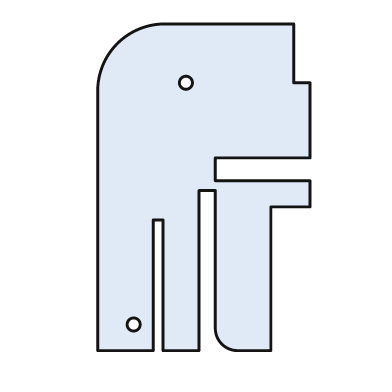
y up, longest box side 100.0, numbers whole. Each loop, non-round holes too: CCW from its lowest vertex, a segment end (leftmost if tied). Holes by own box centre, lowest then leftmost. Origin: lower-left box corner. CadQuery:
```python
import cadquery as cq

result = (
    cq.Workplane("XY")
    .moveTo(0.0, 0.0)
    .lineTo(17.0, 0.0)
    .lineTo(17.0, 40.0)
    .lineTo(20.0, 40.0)
    .lineTo(20.0, 0.0)
    .lineTo(31.0, 0.0)
    .lineTo(31.0, 49.0)
    .lineTo(36.0, 49.0)
    .lineTo(36.0, 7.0)
    .threePointArc((38.0, 2.0), (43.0, 0.0))
    .lineTo(53.0, 0.0)
    .lineTo(53.0, 44.0)
    .lineTo(65.0, 44.0)
    .lineTo(65.0, 52.0)
    .lineTo(36.0, 52.0)
    .lineTo(36.0, 59.0)
    .lineTo(65.0, 59.0)
    .lineTo(65.0, 82.0)
    .lineTo(60.0, 82.0)
    .lineTo(60.0, 100.0)
    .lineTo(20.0, 100.0)
    .threePointArc((6.0, 94.0), (0.0, 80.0))
    .close()
    .moveTo(11.0, 8.0)
    .circle(2.0)
    .moveTo(27.0, 82.0)
    .circle(2.0)
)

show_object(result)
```